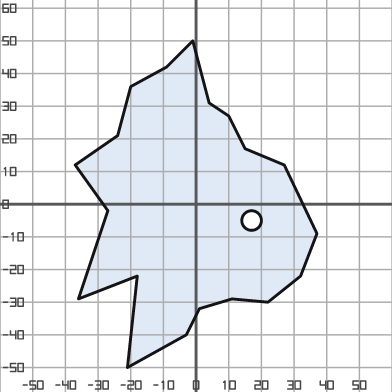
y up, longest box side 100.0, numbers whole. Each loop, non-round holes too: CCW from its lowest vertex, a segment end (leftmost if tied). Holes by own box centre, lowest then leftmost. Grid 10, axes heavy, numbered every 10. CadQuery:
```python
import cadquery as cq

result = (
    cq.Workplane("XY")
    .moveTo(-21.0, -50.0)
    .lineTo(-3.0, -40.0)
    .lineTo(1.0, -32.0)
    .lineTo(11.0, -29.0)
    .lineTo(22.0, -30.0)
    .lineTo(32.0, -22.0)
    .lineTo(37.0, -9.0)
    .lineTo(27.0, 12.0)
    .lineTo(15.0, 17.0)
    .lineTo(10.0, 27.0)
    .lineTo(4.0, 31.0)
    .lineTo(-1.0, 50.0)
    .lineTo(-9.0, 42.0)
    .lineTo(-20.0, 36.0)
    .lineTo(-24.0, 21.0)
    .lineTo(-37.0, 12.0)
    .lineTo(-27.0, -2.0)
    .lineTo(-36.0, -29.0)
    .lineTo(-18.0, -22.0)
    .close()
    .moveTo(17.0, -5.0)
    .circle(3.0)
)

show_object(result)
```